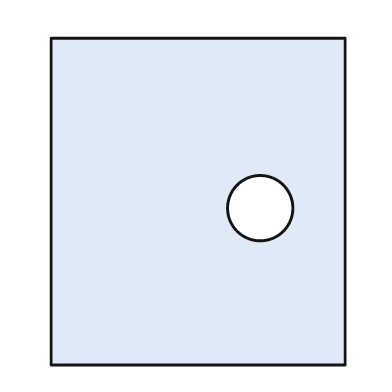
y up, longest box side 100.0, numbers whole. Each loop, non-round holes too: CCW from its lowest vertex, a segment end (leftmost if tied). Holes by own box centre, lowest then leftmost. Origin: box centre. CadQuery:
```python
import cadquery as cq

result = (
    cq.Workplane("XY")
    .moveTo(-45.0, -50.0)
    .lineTo(45.0, -50.0)
    .lineTo(45.0, 50.0)
    .lineTo(-45.0, 50.0)
    .close()
    .moveTo(19.0, -2.0)
    .circle(10.0)
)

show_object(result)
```